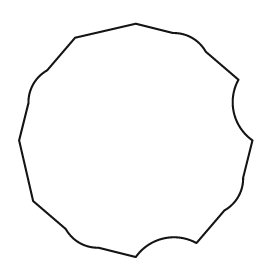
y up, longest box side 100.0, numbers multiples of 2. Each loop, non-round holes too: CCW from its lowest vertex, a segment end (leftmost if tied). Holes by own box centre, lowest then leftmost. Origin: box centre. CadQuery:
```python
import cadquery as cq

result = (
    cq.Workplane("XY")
    .moveTo(0.0, -50.0)
    .threePointArc((12.0, -42.0), (26.0, -44.0))
    .lineTo(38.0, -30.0)
    .threePointArc((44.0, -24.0), (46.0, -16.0))
    .lineTo(50.0, 0.0)
    .threePointArc((42.0, 12.0), (44.0, 26.0))
    .lineTo(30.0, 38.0)
    .threePointArc((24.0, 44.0), (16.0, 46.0))
    .lineTo(0.0, 50.0)
    .lineTo(-26.0, 44.0)
    .lineTo(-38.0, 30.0)
    .threePointArc((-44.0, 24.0), (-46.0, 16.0))
    .lineTo(-50.0, 0.0)
    .lineTo(-44.0, -26.0)
    .lineTo(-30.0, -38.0)
    .threePointArc((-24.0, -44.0), (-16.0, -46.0))
    .close()
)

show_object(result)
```